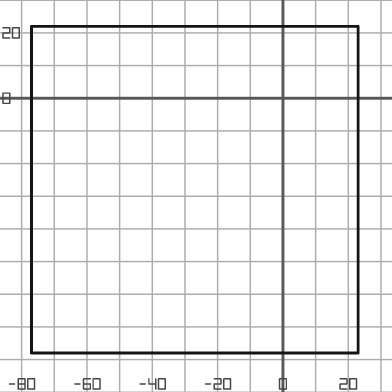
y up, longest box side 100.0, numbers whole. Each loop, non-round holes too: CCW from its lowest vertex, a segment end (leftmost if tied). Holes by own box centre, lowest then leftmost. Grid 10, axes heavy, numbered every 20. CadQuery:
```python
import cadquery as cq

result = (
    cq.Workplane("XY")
    .moveTo(-77.0, -78.0)
    .lineTo(23.0, -78.0)
    .lineTo(23.0, 22.0)
    .lineTo(-77.0, 22.0)
    .close()
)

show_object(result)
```